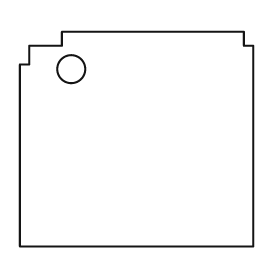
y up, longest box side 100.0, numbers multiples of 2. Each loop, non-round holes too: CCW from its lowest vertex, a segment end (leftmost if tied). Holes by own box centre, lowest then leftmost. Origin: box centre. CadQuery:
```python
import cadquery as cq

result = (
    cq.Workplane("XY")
    .moveTo(-50.0, -46.0)
    .lineTo(50.0, -46.0)
    .lineTo(50.0, 40.0)
    .lineTo(46.0, 40.0)
    .lineTo(46.0, 46.0)
    .lineTo(-32.0, 46.0)
    .lineTo(-32.0, 40.0)
    .lineTo(-46.0, 40.0)
    .lineTo(-46.0, 32.0)
    .lineTo(-50.0, 32.0)
    .close()
    .moveTo(-28.0, 30.0)
    .circle(6.0)
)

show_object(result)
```